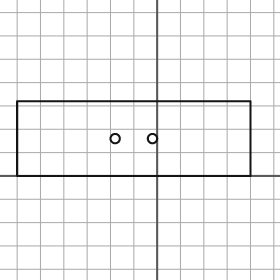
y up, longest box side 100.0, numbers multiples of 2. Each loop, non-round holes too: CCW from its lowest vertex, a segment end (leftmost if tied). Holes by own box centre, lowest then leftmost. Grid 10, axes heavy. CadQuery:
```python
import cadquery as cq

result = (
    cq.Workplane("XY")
    .moveTo(-60.0, 0.0)
    .lineTo(40.0, 0.0)
    .lineTo(40.0, 32.0)
    .lineTo(-60.0, 32.0)
    .close()
    .moveTo(-18.0, 16.0)
    .circle(2.0)
    .moveTo(-2.0, 16.0)
    .circle(2.0)
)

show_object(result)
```